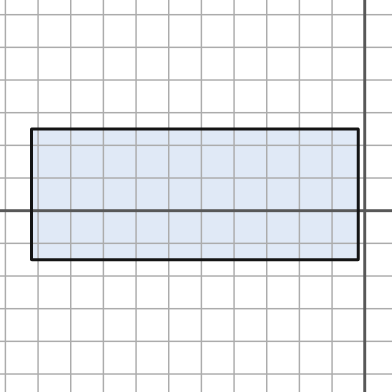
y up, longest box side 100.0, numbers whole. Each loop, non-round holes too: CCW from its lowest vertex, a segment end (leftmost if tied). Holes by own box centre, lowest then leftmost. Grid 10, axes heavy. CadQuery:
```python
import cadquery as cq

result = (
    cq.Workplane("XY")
    .moveTo(-102.0, -15.0)
    .lineTo(-2.0, -15.0)
    .lineTo(-2.0, 25.0)
    .lineTo(-102.0, 25.0)
    .close()
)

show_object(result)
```